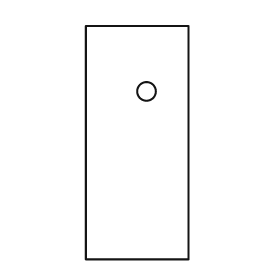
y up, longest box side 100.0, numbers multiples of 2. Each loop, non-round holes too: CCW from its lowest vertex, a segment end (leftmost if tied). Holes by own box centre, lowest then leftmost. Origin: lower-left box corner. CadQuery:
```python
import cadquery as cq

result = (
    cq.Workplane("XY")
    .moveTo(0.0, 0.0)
    .lineTo(44.0, 0.0)
    .lineTo(44.0, 100.0)
    .lineTo(0.0, 100.0)
    .close()
    .moveTo(26.0, 72.0)
    .circle(4.0)
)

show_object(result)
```